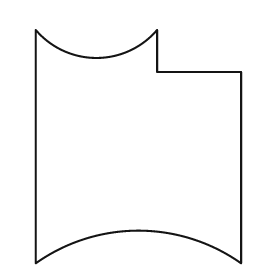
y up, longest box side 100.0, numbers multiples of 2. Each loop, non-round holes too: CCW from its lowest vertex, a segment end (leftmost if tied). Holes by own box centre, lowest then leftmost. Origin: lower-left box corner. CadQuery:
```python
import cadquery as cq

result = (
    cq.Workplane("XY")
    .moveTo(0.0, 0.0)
    .threePointArc((44.0, 14.0), (88.0, 0.0))
    .lineTo(88.0, 82.0)
    .lineTo(52.0, 82.0)
    .lineTo(52.0, 100.0)
    .threePointArc((26.0, 88.0), (0.0, 100.0))
    .close()
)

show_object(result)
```